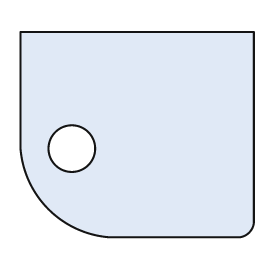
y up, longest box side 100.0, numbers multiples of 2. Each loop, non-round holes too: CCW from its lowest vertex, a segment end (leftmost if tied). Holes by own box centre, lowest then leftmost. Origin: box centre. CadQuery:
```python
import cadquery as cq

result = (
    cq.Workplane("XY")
    .moveTo(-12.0, -44.0)
    .lineTo(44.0, -44.0)
    .threePointArc((48.0, -42.0), (50.0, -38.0))
    .lineTo(50.0, 44.0)
    .lineTo(-50.0, 44.0)
    .lineTo(-50.0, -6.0)
    .threePointArc((-38.0, -32.0), (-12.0, -44.0))
    .close()
    .moveTo(-28.0, -6.0)
    .circle(10.0)
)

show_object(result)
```